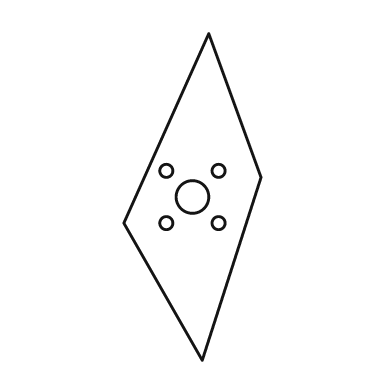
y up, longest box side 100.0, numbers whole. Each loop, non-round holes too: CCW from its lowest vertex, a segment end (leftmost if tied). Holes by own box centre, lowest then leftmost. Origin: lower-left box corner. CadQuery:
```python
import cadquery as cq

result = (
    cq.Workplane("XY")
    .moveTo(24.0, 0.0)
    .lineTo(42.0, 56.0)
    .lineTo(26.0, 100.0)
    .lineTo(0.0, 42.0)
    .close()
    .moveTo(13.0, 42.0)
    .circle(2.0)
    .moveTo(29.0, 42.0)
    .circle(2.0)
    .moveTo(21.0, 50.0)
    .circle(5.0)
    .moveTo(13.0, 58.0)
    .circle(2.0)
    .moveTo(29.0, 58.0)
    .circle(2.0)
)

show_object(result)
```